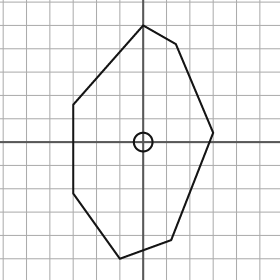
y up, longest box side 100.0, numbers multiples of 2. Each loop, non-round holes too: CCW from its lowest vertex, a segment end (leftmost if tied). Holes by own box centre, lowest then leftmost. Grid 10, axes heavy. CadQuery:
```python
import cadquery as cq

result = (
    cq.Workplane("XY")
    .moveTo(-10.0, -50.0)
    .lineTo(12.0, -42.0)
    .lineTo(30.0, 4.0)
    .lineTo(14.0, 42.0)
    .lineTo(0.0, 50.0)
    .lineTo(-30.0, 16.0)
    .lineTo(-30.0, -22.0)
    .close()
    .moveTo(0.0, 0.0)
    .circle(4.0)
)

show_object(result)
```